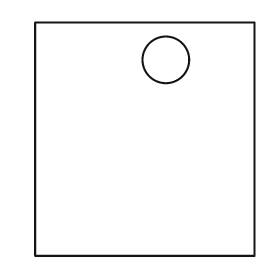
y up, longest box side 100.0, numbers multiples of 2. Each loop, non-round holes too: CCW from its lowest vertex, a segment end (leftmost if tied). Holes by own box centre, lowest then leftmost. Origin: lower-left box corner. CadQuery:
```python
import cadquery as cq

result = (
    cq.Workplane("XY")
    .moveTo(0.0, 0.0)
    .lineTo(94.0, 0.0)
    .lineTo(94.0, 100.0)
    .lineTo(0.0, 100.0)
    .close()
    .moveTo(56.0, 84.0)
    .circle(10.0)
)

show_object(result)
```